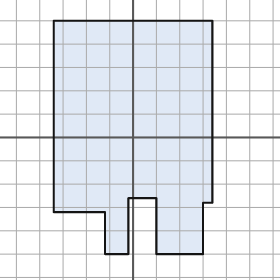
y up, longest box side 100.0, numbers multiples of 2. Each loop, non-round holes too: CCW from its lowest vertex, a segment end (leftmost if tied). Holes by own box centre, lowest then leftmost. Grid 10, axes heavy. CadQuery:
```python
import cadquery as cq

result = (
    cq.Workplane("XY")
    .moveTo(-12.0, -50.0)
    .lineTo(-2.0, -50.0)
    .lineTo(-2.0, -26.0)
    .lineTo(10.0, -26.0)
    .lineTo(10.0, -50.0)
    .lineTo(30.0, -50.0)
    .lineTo(30.0, -28.0)
    .lineTo(34.0, -28.0)
    .lineTo(34.0, 50.0)
    .lineTo(-34.0, 50.0)
    .lineTo(-34.0, -32.0)
    .lineTo(-12.0, -32.0)
    .close()
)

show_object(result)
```